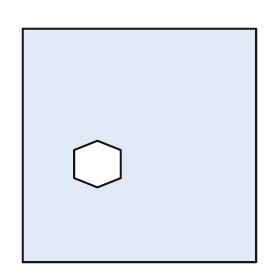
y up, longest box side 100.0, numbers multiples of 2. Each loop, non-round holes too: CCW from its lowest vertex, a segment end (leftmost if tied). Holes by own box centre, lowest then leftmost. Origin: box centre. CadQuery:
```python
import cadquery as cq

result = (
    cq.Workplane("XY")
    .moveTo(-50.0, -50.0)
    .lineTo(50.0, -50.0)
    .lineTo(50.0, 50.0)
    .lineTo(-50.0, 50.0)
    .close()
    .moveTo(-18.0, -18.0)
    .lineTo(-8.0, -14.0)
    .lineTo(-8.0, -2.0)
    .lineTo(-18.0, 2.0)
    .lineTo(-28.0, -2.0)
    .lineTo(-28.0, -14.0)
    .close()
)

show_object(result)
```